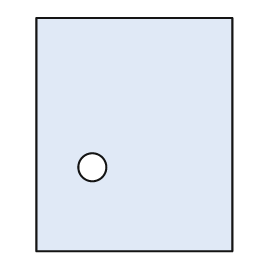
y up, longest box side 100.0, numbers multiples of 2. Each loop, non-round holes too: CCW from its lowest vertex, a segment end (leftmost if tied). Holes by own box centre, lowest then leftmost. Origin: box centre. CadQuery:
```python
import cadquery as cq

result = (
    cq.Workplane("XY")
    .moveTo(-42.0, -50.0)
    .lineTo(42.0, -50.0)
    .lineTo(42.0, 50.0)
    .lineTo(-42.0, 50.0)
    .close()
    .moveTo(-18.0, -14.0)
    .circle(6.0)
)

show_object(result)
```